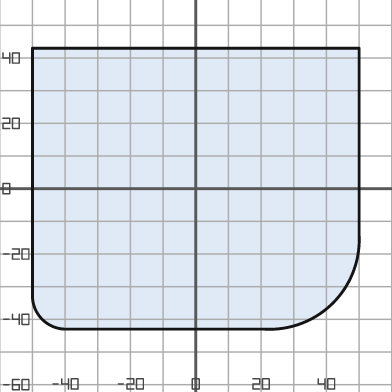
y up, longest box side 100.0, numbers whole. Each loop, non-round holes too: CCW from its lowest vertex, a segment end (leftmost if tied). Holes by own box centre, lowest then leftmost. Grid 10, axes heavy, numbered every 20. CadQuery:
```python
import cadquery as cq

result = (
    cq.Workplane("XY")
    .moveTo(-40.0, -43.0)
    .lineTo(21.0, -43.0)
    .threePointArc((42.0, -35.0), (50.0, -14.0))
    .lineTo(50.0, 43.0)
    .lineTo(-50.0, 43.0)
    .lineTo(-50.0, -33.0)
    .threePointArc((-47.0, -40.0), (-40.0, -43.0))
    .close()
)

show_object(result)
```